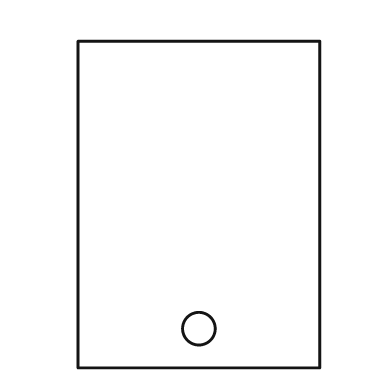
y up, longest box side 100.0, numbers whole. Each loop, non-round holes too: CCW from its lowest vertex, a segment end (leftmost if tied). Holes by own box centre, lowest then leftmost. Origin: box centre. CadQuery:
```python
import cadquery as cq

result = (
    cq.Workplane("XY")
    .moveTo(-37.0, -50.0)
    .lineTo(37.0, -50.0)
    .lineTo(37.0, 50.0)
    .lineTo(-37.0, 50.0)
    .close()
    .moveTo(0.0, -38.0)
    .circle(5.0)
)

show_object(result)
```